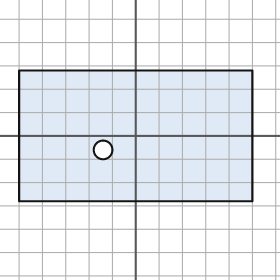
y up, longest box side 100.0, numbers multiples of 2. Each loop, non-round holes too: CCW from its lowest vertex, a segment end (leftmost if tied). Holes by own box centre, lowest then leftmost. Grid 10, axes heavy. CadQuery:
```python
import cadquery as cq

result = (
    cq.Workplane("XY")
    .moveTo(-50.0, -28.0)
    .lineTo(50.0, -28.0)
    .lineTo(50.0, 28.0)
    .lineTo(-50.0, 28.0)
    .close()
    .moveTo(-14.0, -6.0)
    .circle(4.0)
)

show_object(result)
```